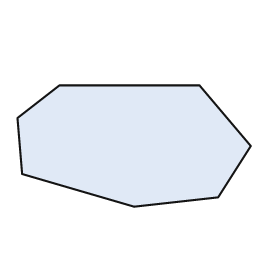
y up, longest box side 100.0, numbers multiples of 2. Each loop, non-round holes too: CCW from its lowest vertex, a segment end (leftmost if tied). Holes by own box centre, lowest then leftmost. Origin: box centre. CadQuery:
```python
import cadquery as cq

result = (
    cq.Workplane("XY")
    .moveTo(0.0, -26.0)
    .lineTo(36.0, -22.0)
    .lineTo(50.0, 0.0)
    .lineTo(28.0, 26.0)
    .lineTo(-32.0, 26.0)
    .lineTo(-50.0, 12.0)
    .lineTo(-48.0, -12.0)
    .close()
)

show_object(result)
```